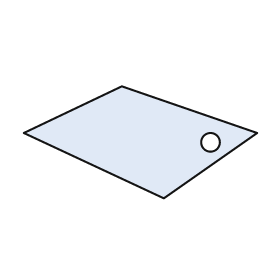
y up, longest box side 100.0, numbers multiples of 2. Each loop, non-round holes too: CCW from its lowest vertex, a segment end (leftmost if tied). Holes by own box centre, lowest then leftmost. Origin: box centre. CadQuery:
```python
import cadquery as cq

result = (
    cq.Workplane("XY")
    .moveTo(10.0, -24.0)
    .lineTo(50.0, 4.0)
    .lineTo(-8.0, 24.0)
    .lineTo(-50.0, 4.0)
    .close()
    .moveTo(30.0, 0.0)
    .circle(4.0)
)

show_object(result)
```